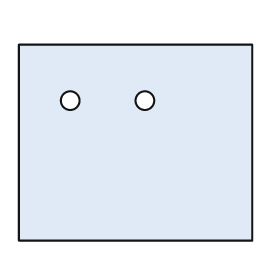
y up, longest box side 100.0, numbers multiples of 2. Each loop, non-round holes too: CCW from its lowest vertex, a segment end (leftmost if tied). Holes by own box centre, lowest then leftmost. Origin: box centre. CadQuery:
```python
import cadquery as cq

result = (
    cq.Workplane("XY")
    .moveTo(-50.0, -42.0)
    .lineTo(50.0, -42.0)
    .lineTo(50.0, 42.0)
    .lineTo(-50.0, 42.0)
    .close()
    .moveTo(-28.0, 18.0)
    .circle(4.0)
    .moveTo(4.0, 18.0)
    .circle(4.0)
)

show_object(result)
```